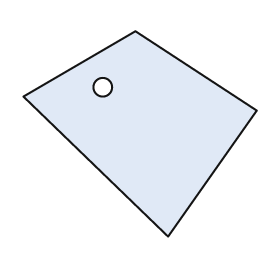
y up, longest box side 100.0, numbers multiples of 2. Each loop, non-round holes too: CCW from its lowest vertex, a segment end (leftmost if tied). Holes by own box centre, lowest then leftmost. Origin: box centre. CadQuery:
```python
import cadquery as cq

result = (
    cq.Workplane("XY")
    .moveTo(12.0, -44.0)
    .lineTo(50.0, 10.0)
    .lineTo(-2.0, 44.0)
    .lineTo(-50.0, 16.0)
    .close()
    .moveTo(-16.0, 20.0)
    .circle(4.0)
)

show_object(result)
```